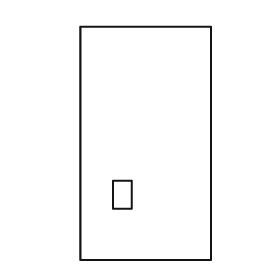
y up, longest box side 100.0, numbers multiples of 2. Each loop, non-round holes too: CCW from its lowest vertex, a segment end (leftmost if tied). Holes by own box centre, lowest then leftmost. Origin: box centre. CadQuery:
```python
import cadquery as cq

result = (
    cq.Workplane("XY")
    .moveTo(-28.0, -50.0)
    .lineTo(28.0, -50.0)
    .lineTo(28.0, 50.0)
    .lineTo(-28.0, 50.0)
    .close()
    .moveTo(-14.0, -28.0)
    .lineTo(-6.0, -28.0)
    .lineTo(-6.0, -16.0)
    .lineTo(-14.0, -16.0)
    .close()
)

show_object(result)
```